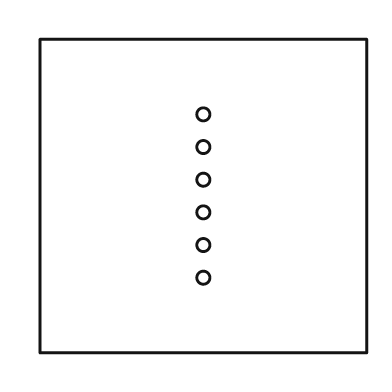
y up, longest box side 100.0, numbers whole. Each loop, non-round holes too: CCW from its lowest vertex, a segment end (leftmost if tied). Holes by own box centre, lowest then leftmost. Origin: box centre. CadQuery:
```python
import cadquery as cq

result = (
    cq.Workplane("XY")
    .moveTo(-50.0, -48.0)
    .lineTo(50.0, -48.0)
    .lineTo(50.0, 48.0)
    .lineTo(-50.0, 48.0)
    .close()
    .moveTo(0.0, -25.0)
    .circle(2.0)
    .moveTo(0.0, -15.0)
    .circle(2.0)
    .moveTo(0.0, -5.0)
    .circle(2.0)
    .moveTo(0.0, 5.0)
    .circle(2.0)
    .moveTo(0.0, 15.0)
    .circle(2.0)
    .moveTo(0.0, 25.0)
    .circle(2.0)
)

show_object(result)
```